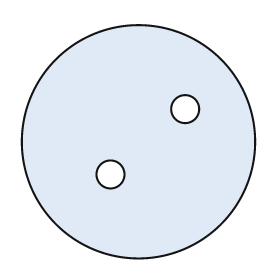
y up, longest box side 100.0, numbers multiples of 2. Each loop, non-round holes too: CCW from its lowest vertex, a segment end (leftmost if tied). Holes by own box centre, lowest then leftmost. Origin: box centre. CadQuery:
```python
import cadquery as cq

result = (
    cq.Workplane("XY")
    .moveTo(0.0, 0.0)
    .circle(50.0)
    .moveTo(-12.0, -14.0)
    .circle(6.0)
    .moveTo(20.0, 14.0)
    .circle(6.0)
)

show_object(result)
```